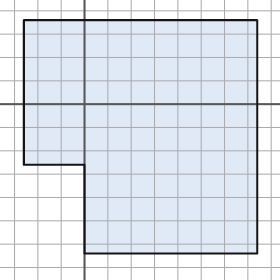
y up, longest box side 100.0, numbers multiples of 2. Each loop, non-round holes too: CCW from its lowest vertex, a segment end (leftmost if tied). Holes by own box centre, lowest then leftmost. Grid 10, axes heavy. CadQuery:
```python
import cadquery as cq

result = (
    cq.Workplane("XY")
    .moveTo(0.0, -64.0)
    .lineTo(74.0, -64.0)
    .lineTo(74.0, 36.0)
    .lineTo(-26.0, 36.0)
    .lineTo(-26.0, -26.0)
    .lineTo(0.0, -26.0)
    .close()
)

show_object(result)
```